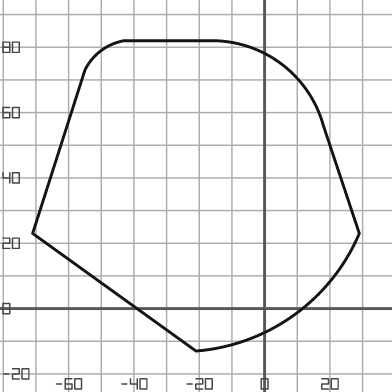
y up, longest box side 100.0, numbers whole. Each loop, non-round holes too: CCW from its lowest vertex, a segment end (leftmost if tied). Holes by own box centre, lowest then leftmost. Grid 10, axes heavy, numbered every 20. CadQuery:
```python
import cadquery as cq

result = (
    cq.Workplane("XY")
    .moveTo(-21.0, -13.0)
    .threePointArc((9.0, -2.0), (29.0, 23.0))
    .lineTo(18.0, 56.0)
    .threePointArc((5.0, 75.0), (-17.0, 82.0))
    .lineTo(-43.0, 82.0)
    .threePointArc((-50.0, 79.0), (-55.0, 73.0))
    .lineTo(-71.0, 23.0)
    .close()
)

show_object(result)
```